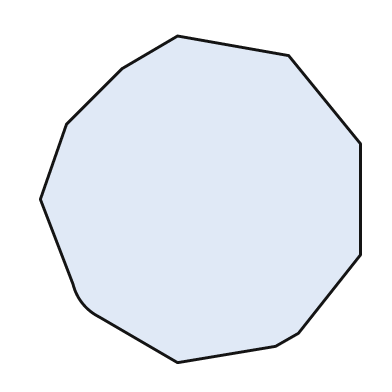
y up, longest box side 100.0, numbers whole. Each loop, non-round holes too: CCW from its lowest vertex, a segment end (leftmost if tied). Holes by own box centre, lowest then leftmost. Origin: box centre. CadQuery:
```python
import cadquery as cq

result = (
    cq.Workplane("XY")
    .moveTo(-7.0, -50.0)
    .lineTo(23.0, -45.0)
    .lineTo(30.0, -41.0)
    .lineTo(49.0, -17.0)
    .lineTo(49.0, 17.0)
    .lineTo(27.0, 44.0)
    .lineTo(-7.0, 50.0)
    .lineTo(-24.0, 40.0)
    .lineTo(-41.0, 23.0)
    .lineTo(-49.0, 0.0)
    .lineTo(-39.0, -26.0)
    .threePointArc((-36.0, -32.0), (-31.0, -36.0))
    .close()
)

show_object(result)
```